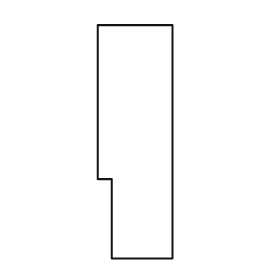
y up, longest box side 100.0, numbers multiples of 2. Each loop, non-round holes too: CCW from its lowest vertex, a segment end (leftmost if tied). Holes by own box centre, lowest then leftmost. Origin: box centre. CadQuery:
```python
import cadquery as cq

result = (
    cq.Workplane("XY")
    .moveTo(-10.0, -50.0)
    .lineTo(16.0, -50.0)
    .lineTo(16.0, 50.0)
    .lineTo(-16.0, 50.0)
    .lineTo(-16.0, -16.0)
    .lineTo(-10.0, -16.0)
    .close()
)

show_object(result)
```